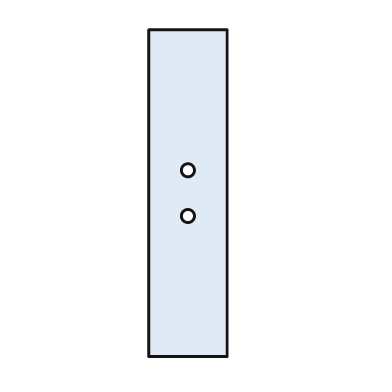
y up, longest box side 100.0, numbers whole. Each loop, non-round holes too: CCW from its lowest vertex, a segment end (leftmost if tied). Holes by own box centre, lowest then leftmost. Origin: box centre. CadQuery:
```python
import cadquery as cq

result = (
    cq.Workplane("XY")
    .moveTo(-12.0, -50.0)
    .lineTo(12.0, -50.0)
    .lineTo(12.0, 50.0)
    .lineTo(-12.0, 50.0)
    .close()
    .moveTo(0.0, -7.0)
    .circle(2.0)
    .moveTo(0.0, 7.0)
    .circle(2.0)
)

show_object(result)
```